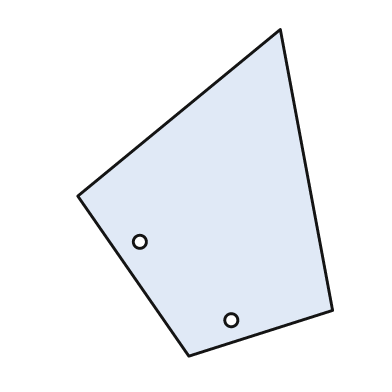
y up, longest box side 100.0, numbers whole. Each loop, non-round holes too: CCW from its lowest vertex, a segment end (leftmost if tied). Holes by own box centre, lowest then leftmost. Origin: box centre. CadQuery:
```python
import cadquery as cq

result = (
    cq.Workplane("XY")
    .moveTo(-5.0, -50.0)
    .lineTo(39.0, -36.0)
    .lineTo(23.0, 50.0)
    .lineTo(-39.0, -1.0)
    .close()
    .moveTo(8.0, -39.0)
    .circle(2.0)
    .moveTo(-20.0, -15.0)
    .circle(2.0)
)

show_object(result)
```